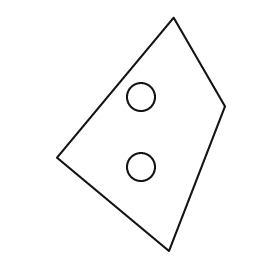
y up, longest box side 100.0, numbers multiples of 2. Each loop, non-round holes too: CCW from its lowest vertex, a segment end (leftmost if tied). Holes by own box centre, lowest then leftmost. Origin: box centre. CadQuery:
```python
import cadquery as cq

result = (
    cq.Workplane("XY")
    .moveTo(12.0, -50.0)
    .lineTo(36.0, 12.0)
    .lineTo(14.0, 50.0)
    .lineTo(-36.0, -10.0)
    .close()
    .moveTo(0.0, -14.0)
    .circle(6.0)
    .moveTo(0.0, 16.0)
    .circle(6.0)
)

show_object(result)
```